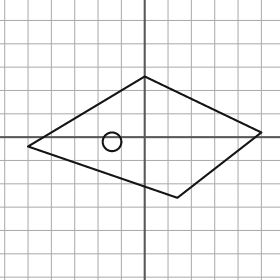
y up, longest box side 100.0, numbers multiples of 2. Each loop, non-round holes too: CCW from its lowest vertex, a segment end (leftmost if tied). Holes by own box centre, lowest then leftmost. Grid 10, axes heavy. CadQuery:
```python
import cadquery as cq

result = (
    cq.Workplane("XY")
    .moveTo(14.0, -26.0)
    .lineTo(50.0, 2.0)
    .lineTo(0.0, 26.0)
    .lineTo(-50.0, -4.0)
    .close()
    .moveTo(-14.0, -2.0)
    .circle(4.0)
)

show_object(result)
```